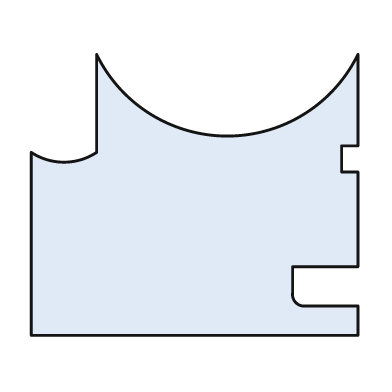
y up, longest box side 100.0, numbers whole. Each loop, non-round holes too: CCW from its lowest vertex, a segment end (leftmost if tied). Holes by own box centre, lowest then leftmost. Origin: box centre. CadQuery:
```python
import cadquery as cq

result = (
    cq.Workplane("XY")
    .moveTo(-50.0, -43.0)
    .lineTo(50.0, -43.0)
    .lineTo(50.0, -34.0)
    .lineTo(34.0, -34.0)
    .threePointArc((31.0, -33.0), (30.0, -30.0))
    .lineTo(30.0, -22.0)
    .lineTo(50.0, -22.0)
    .lineTo(50.0, 7.0)
    .lineTo(45.0, 7.0)
    .lineTo(45.0, 15.0)
    .lineTo(50.0, 15.0)
    .lineTo(50.0, 43.0)
    .threePointArc((10.0, 18.0), (-30.0, 43.0))
    .lineTo(-30.0, 13.0)
    .threePointArc((-40.0, 10.0), (-50.0, 13.0))
    .close()
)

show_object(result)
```